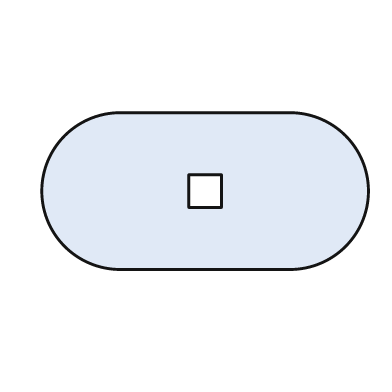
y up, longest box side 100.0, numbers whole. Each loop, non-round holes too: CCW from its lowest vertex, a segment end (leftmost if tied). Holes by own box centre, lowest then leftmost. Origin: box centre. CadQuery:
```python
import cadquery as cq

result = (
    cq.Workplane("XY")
    .moveTo(-26.0, -24.0)
    .lineTo(26.0, -24.0)
    .threePointArc((50.0, 0.0), (26.0, 24.0))
    .lineTo(-26.0, 24.0)
    .threePointArc((-50.0, 0.0), (-26.0, -24.0))
    .close()
    .moveTo(-5.0, -5.0)
    .lineTo(5.0, -5.0)
    .lineTo(5.0, 5.0)
    .lineTo(-5.0, 5.0)
    .close()
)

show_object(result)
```